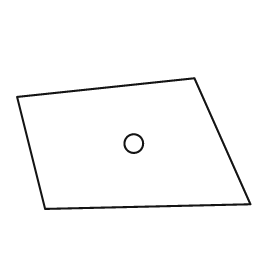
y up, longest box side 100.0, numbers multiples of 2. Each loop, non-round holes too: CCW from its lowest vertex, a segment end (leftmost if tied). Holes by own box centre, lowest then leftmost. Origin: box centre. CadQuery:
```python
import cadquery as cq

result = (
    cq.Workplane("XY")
    .moveTo(-38.0, -28.0)
    .lineTo(50.0, -26.0)
    .lineTo(26.0, 28.0)
    .lineTo(-50.0, 20.0)
    .close()
    .moveTo(0.0, 0.0)
    .circle(4.0)
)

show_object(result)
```